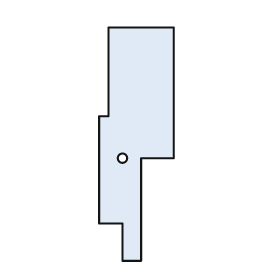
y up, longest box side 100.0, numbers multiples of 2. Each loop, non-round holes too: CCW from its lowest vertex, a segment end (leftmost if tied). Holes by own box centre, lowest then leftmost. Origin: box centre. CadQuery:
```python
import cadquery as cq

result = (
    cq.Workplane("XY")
    .moveTo(-6.0, -50.0)
    .lineTo(2.0, -50.0)
    .lineTo(2.0, -6.0)
    .lineTo(16.0, -6.0)
    .lineTo(16.0, 50.0)
    .lineTo(-12.0, 50.0)
    .lineTo(-12.0, 12.0)
    .lineTo(-16.0, 12.0)
    .lineTo(-16.0, -34.0)
    .lineTo(-6.0, -34.0)
    .close()
    .moveTo(-6.0, -6.0)
    .circle(2.0)
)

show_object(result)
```